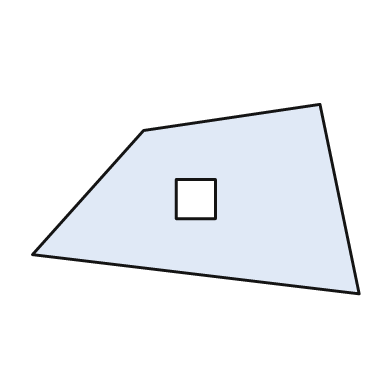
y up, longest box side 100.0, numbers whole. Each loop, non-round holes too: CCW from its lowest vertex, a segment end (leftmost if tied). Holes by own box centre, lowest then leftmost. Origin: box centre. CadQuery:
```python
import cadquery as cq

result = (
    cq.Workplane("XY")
    .moveTo(50.0, -29.0)
    .lineTo(38.0, 29.0)
    .lineTo(-16.0, 21.0)
    .lineTo(-50.0, -17.0)
    .close()
    .moveTo(-6.0, -6.0)
    .lineTo(6.0, -6.0)
    .lineTo(6.0, 6.0)
    .lineTo(-6.0, 6.0)
    .close()
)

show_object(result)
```